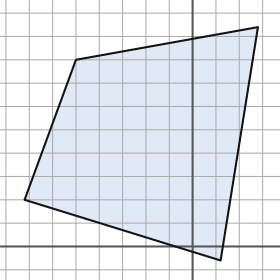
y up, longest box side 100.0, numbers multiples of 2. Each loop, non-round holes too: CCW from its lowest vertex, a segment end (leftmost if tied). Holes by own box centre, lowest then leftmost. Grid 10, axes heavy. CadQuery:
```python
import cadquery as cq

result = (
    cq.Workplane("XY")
    .moveTo(12.0, -6.0)
    .lineTo(28.0, 94.0)
    .lineTo(-50.0, 80.0)
    .lineTo(-72.0, 20.0)
    .close()
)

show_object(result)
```